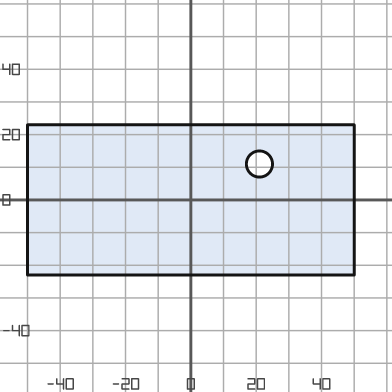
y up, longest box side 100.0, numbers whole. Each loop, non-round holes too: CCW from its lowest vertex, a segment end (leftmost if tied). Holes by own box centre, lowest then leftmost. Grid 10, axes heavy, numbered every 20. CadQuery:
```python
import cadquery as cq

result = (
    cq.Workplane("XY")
    .moveTo(-50.0, -23.0)
    .lineTo(50.0, -23.0)
    .lineTo(50.0, 23.0)
    .lineTo(-50.0, 23.0)
    .close()
    .moveTo(21.0, 11.0)
    .circle(4.0)
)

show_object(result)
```